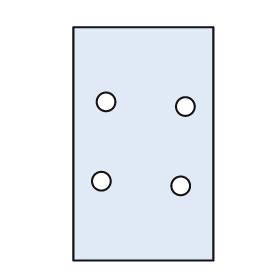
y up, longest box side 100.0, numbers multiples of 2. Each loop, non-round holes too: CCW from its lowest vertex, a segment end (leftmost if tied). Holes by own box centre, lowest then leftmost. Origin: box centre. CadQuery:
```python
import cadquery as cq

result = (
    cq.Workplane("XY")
    .moveTo(-30.0, -50.0)
    .lineTo(30.0, -50.0)
    .lineTo(30.0, 50.0)
    .lineTo(-30.0, 50.0)
    .close()
    .moveTo(16.0, -18.0)
    .circle(4.0)
    .moveTo(-18.0, -16.0)
    .circle(4.0)
    .moveTo(18.0, 16.0)
    .circle(4.0)
    .moveTo(-16.0, 18.0)
    .circle(4.0)
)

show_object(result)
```